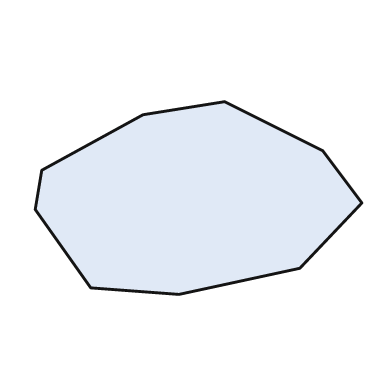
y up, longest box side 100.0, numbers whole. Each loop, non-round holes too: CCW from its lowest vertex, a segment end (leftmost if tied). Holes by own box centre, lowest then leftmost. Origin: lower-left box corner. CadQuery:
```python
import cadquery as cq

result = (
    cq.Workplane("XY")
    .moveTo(44.0, 0.0)
    .lineTo(81.0, 8.0)
    .lineTo(100.0, 28.0)
    .lineTo(88.0, 44.0)
    .lineTo(58.0, 59.0)
    .lineTo(33.0, 55.0)
    .lineTo(2.0, 38.0)
    .lineTo(0.0, 26.0)
    .lineTo(17.0, 2.0)
    .close()
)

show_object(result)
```